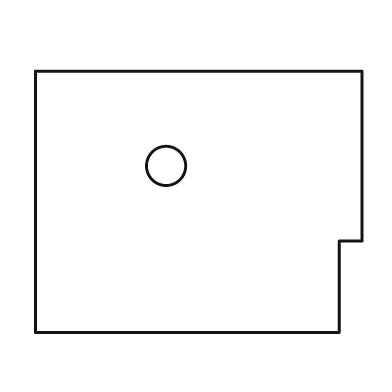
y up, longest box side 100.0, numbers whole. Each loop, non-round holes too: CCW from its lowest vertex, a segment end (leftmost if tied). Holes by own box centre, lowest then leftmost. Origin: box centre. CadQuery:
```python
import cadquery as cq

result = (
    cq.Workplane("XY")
    .moveTo(-50.0, -40.0)
    .lineTo(43.0, -40.0)
    .lineTo(43.0, -12.0)
    .lineTo(50.0, -12.0)
    .lineTo(50.0, 40.0)
    .lineTo(-50.0, 40.0)
    .close()
    .moveTo(-10.0, 11.0)
    .circle(6.0)
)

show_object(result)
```